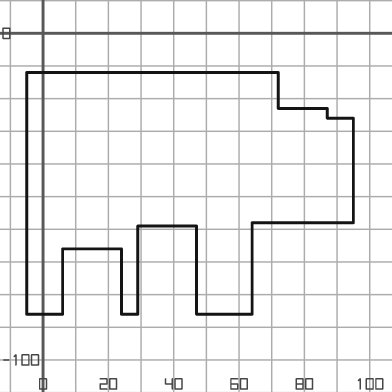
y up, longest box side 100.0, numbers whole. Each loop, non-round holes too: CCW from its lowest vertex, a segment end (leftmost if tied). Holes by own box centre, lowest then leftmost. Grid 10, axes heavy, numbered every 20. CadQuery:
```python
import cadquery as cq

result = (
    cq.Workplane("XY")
    .moveTo(-5.0, -86.0)
    .lineTo(6.0, -86.0)
    .lineTo(6.0, -66.0)
    .lineTo(24.0, -66.0)
    .lineTo(24.0, -86.0)
    .lineTo(29.0, -86.0)
    .lineTo(29.0, -59.0)
    .lineTo(47.0, -59.0)
    .lineTo(47.0, -86.0)
    .lineTo(64.0, -86.0)
    .lineTo(64.0, -58.0)
    .lineTo(95.0, -58.0)
    .lineTo(95.0, -26.0)
    .lineTo(87.0, -26.0)
    .lineTo(87.0, -23.0)
    .lineTo(72.0, -23.0)
    .lineTo(72.0, -12.0)
    .lineTo(-5.0, -12.0)
    .close()
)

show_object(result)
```